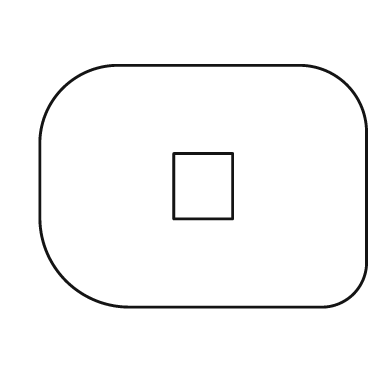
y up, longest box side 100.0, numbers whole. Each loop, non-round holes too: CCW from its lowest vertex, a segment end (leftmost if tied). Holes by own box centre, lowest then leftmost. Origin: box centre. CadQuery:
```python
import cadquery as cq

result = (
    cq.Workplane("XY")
    .moveTo(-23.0, -37.0)
    .lineTo(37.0, -37.0)
    .threePointArc((46.0, -33.0), (50.0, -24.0))
    .lineTo(50.0, 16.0)
    .threePointArc((44.0, 31.0), (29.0, 37.0))
    .lineTo(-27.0, 37.0)
    .threePointArc((-43.0, 30.0), (-50.0, 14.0))
    .lineTo(-50.0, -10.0)
    .threePointArc((-42.0, -29.0), (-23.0, -37.0))
    .close()
    .moveTo(-9.0, -10.0)
    .lineTo(9.0, -10.0)
    .lineTo(9.0, 10.0)
    .lineTo(-9.0, 10.0)
    .close()
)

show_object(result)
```